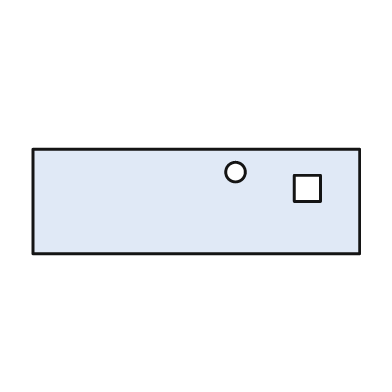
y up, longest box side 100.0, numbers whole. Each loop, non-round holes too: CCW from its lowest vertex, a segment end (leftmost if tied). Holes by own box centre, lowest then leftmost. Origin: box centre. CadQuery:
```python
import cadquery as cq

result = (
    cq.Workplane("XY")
    .moveTo(-50.0, -16.0)
    .lineTo(50.0, -16.0)
    .lineTo(50.0, 16.0)
    .lineTo(-50.0, 16.0)
    .close()
    .moveTo(30.0, 0.0)
    .lineTo(38.0, 0.0)
    .lineTo(38.0, 8.0)
    .lineTo(30.0, 8.0)
    .close()
    .moveTo(12.0, 9.0)
    .circle(3.0)
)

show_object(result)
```